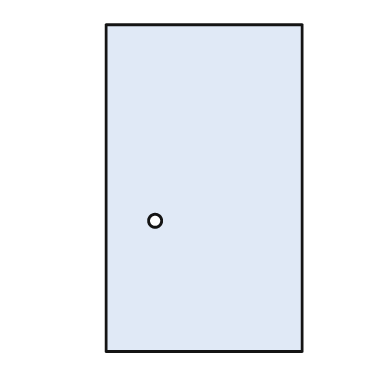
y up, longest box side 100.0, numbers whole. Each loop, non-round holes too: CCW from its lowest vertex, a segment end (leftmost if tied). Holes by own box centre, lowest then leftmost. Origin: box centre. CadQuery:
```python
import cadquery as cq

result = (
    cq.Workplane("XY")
    .moveTo(-30.0, -50.0)
    .lineTo(30.0, -50.0)
    .lineTo(30.0, 50.0)
    .lineTo(-30.0, 50.0)
    .close()
    .moveTo(-15.0, -10.0)
    .circle(2.0)
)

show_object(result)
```